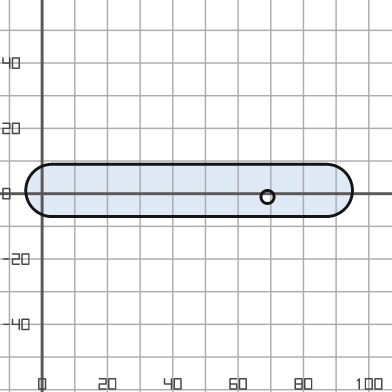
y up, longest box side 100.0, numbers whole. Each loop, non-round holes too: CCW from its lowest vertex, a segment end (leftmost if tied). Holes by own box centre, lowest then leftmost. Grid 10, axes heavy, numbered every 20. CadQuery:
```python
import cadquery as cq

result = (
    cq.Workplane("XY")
    .moveTo(3.0, -7.0)
    .lineTo(87.0, -7.0)
    .threePointArc((95.0, 1.0), (87.0, 9.0))
    .lineTo(3.0, 9.0)
    .threePointArc((-5.0, 1.0), (3.0, -7.0))
    .close()
    .moveTo(69.0, -1.0)
    .circle(2.0)
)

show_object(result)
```